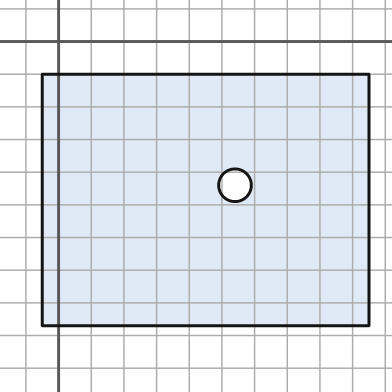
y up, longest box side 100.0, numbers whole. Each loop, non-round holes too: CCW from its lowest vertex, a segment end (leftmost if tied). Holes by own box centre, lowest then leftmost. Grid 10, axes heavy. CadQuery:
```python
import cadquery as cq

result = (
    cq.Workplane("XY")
    .moveTo(-5.0, -87.0)
    .lineTo(95.0, -87.0)
    .lineTo(95.0, -10.0)
    .lineTo(-5.0, -10.0)
    .close()
    .moveTo(54.0, -44.0)
    .circle(5.0)
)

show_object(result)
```